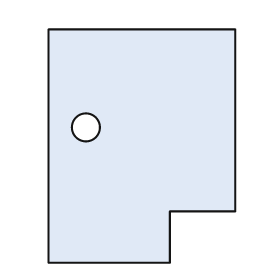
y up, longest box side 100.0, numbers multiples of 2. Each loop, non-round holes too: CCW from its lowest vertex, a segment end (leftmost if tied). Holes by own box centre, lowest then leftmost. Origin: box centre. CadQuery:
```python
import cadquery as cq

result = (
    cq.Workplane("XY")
    .moveTo(-40.0, -50.0)
    .lineTo(12.0, -50.0)
    .lineTo(12.0, -28.0)
    .lineTo(40.0, -28.0)
    .lineTo(40.0, 50.0)
    .lineTo(-40.0, 50.0)
    .close()
    .moveTo(-24.0, 8.0)
    .circle(6.0)
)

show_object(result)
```